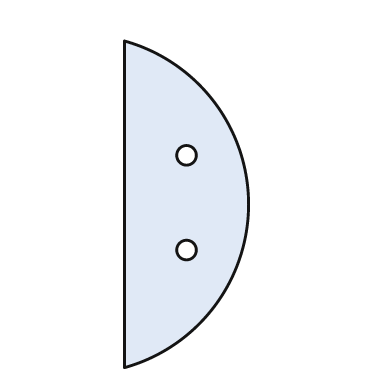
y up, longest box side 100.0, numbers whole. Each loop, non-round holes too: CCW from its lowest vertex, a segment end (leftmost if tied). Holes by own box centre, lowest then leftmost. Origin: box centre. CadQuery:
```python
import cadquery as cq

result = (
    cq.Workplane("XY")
    .moveTo(-19.0, -50.0)
    .threePointArc((19.0, 0.0), (-19.0, 50.0))
    .close()
    .moveTo(0.0, -14.0)
    .circle(3.0)
    .moveTo(0.0, 15.0)
    .circle(3.0)
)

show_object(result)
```